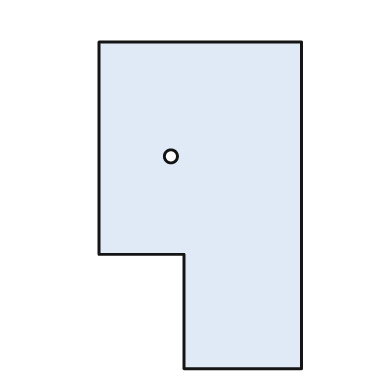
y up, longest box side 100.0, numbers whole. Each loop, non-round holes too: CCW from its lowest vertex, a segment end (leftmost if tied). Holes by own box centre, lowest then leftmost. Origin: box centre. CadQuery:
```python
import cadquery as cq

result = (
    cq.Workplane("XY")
    .moveTo(-5.0, -50.0)
    .lineTo(31.0, -50.0)
    .lineTo(31.0, 50.0)
    .lineTo(-31.0, 50.0)
    .lineTo(-31.0, -15.0)
    .lineTo(-5.0, -15.0)
    .close()
    .moveTo(-9.0, 15.0)
    .circle(2.0)
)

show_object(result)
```